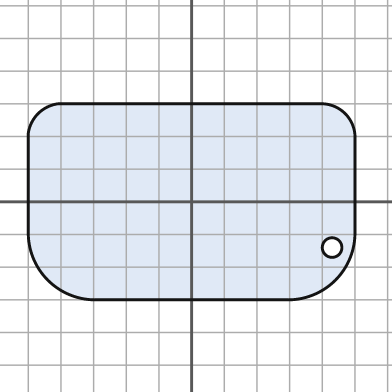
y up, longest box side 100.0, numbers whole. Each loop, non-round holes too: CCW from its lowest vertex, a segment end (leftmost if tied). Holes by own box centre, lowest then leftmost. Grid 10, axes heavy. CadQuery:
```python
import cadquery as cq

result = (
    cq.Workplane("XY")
    .moveTo(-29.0, -30.0)
    .lineTo(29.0, -30.0)
    .threePointArc((44.0, -24.0), (50.0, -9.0))
    .lineTo(50.0, 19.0)
    .threePointArc((47.0, 27.0), (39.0, 30.0))
    .lineTo(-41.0, 30.0)
    .threePointArc((-47.0, 27.0), (-50.0, 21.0))
    .lineTo(-50.0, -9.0)
    .threePointArc((-44.0, -24.0), (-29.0, -30.0))
    .close()
    .moveTo(43.0, -14.0)
    .circle(3.0)
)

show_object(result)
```